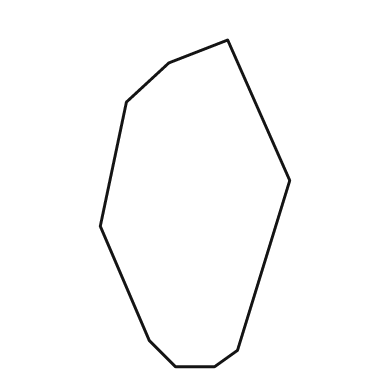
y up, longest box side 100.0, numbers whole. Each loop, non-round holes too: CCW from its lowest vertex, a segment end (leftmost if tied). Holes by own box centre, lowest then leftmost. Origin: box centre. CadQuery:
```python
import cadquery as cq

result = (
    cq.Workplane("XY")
    .moveTo(-6.0, -50.0)
    .lineTo(6.0, -50.0)
    .lineTo(13.0, -45.0)
    .lineTo(29.0, 7.0)
    .lineTo(10.0, 50.0)
    .lineTo(-8.0, 43.0)
    .lineTo(-21.0, 31.0)
    .lineTo(-29.0, -7.0)
    .lineTo(-14.0, -42.0)
    .close()
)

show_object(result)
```